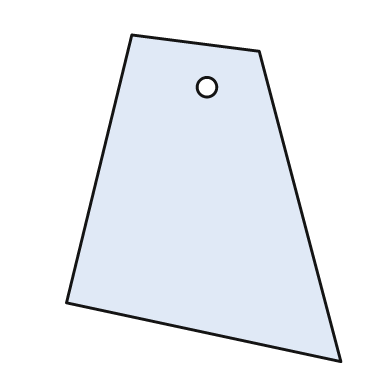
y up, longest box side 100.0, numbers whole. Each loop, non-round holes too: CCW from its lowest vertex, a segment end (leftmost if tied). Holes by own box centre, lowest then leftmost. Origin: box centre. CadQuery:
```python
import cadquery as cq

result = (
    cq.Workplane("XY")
    .moveTo(42.0, -50.0)
    .lineTo(17.0, 45.0)
    .lineTo(-22.0, 50.0)
    .lineTo(-42.0, -32.0)
    .close()
    .moveTo(1.0, 34.0)
    .circle(3.0)
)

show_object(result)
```